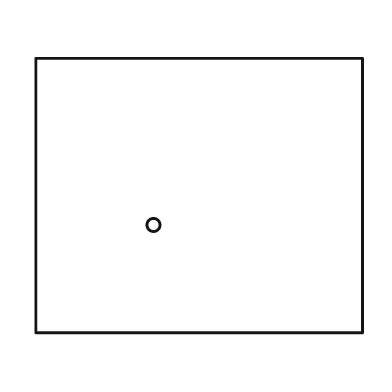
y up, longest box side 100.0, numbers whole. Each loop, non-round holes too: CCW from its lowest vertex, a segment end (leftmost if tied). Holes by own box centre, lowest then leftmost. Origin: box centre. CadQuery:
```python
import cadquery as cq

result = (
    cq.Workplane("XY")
    .moveTo(-50.0, -42.0)
    .lineTo(50.0, -42.0)
    .lineTo(50.0, 42.0)
    .lineTo(-50.0, 42.0)
    .close()
    .moveTo(-14.0, -9.0)
    .circle(2.0)
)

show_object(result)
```